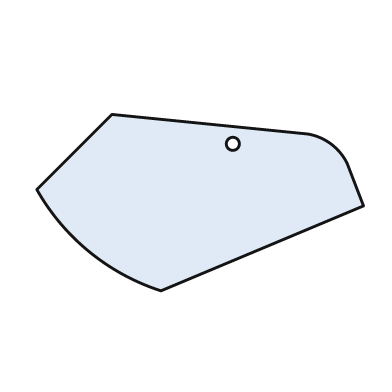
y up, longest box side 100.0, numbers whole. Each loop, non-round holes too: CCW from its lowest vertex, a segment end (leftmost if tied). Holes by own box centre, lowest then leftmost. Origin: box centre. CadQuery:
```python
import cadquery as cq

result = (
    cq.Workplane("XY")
    .moveTo(-12.0, -27.0)
    .lineTo(50.0, -1.0)
    .lineTo(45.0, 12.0)
    .threePointArc((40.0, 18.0), (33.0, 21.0))
    .lineTo(-27.0, 27.0)
    .lineTo(-50.0, 4.0)
    .threePointArc((-34.0, -15.0), (-12.0, -27.0))
    .close()
    .moveTo(10.0, 18.0)
    .circle(2.0)
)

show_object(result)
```